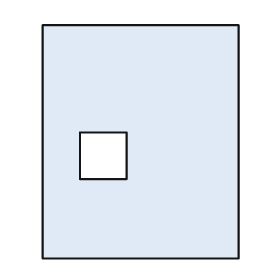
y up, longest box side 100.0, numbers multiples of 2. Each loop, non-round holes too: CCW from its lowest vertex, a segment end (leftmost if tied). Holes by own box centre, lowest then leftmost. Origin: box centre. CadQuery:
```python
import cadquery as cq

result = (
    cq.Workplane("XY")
    .moveTo(-42.0, -50.0)
    .lineTo(42.0, -50.0)
    .lineTo(42.0, 50.0)
    .lineTo(-42.0, 50.0)
    .close()
    .moveTo(-26.0, -16.0)
    .lineTo(-6.0, -16.0)
    .lineTo(-6.0, 4.0)
    .lineTo(-26.0, 4.0)
    .close()
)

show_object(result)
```